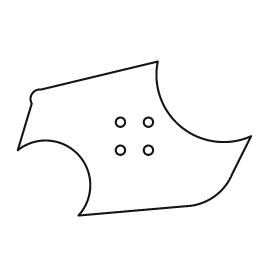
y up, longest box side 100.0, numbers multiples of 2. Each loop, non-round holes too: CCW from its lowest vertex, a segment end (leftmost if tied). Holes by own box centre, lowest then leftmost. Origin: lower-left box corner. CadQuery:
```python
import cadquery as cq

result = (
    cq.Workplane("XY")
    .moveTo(26.0, 0.0)
    .lineTo(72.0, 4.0)
    .threePointArc((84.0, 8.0), (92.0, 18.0))
    .lineTo(100.0, 34.0)
    .threePointArc((70.0, 38.0), (60.0, 66.0))
    .lineTo(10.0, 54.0)
    .threePointArc((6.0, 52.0), (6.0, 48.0))
    .lineTo(0.0, 28.0)
    .threePointArc((26.0, 26.0), (26.0, 0.0))
    .close()
    .moveTo(44.0, 28.0)
    .circle(2.0)
    .moveTo(56.0, 28.0)
    .circle(2.0)
    .moveTo(44.0, 40.0)
    .circle(2.0)
    .moveTo(56.0, 40.0)
    .circle(2.0)
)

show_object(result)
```